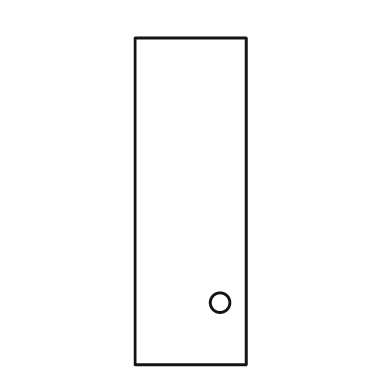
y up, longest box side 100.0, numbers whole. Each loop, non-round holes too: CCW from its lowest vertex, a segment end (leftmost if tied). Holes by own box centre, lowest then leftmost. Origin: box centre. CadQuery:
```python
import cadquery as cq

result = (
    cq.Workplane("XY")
    .moveTo(-17.0, -50.0)
    .lineTo(17.0, -50.0)
    .lineTo(17.0, 50.0)
    .lineTo(-17.0, 50.0)
    .close()
    .moveTo(9.0, -31.0)
    .circle(3.0)
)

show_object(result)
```